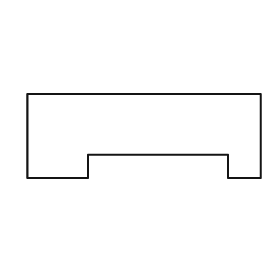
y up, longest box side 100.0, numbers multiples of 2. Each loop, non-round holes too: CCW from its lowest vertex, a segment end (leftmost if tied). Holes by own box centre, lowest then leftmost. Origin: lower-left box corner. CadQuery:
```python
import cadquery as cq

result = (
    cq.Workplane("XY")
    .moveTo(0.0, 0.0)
    .lineTo(26.0, 0.0)
    .lineTo(26.0, 10.0)
    .lineTo(86.0, 10.0)
    .lineTo(86.0, 0.0)
    .lineTo(100.0, 0.0)
    .lineTo(100.0, 36.0)
    .lineTo(0.0, 36.0)
    .close()
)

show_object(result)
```